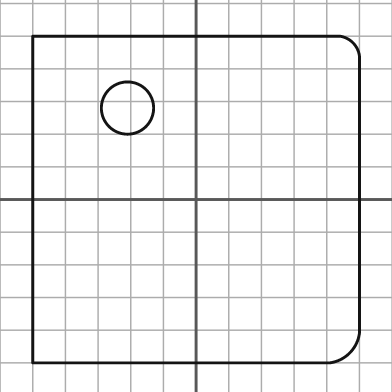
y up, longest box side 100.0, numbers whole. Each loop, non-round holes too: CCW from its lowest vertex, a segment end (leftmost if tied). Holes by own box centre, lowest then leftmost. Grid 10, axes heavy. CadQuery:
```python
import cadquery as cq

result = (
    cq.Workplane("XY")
    .moveTo(-50.0, -50.0)
    .lineTo(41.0, -50.0)
    .threePointArc((47.0, -47.0), (50.0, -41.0))
    .lineTo(50.0, 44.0)
    .threePointArc((48.0, 48.0), (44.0, 50.0))
    .lineTo(-50.0, 50.0)
    .close()
    .moveTo(-21.0, 28.0)
    .circle(8.0)
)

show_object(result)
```